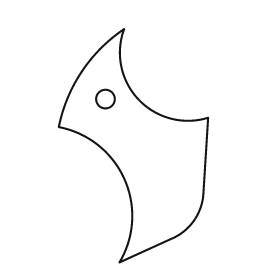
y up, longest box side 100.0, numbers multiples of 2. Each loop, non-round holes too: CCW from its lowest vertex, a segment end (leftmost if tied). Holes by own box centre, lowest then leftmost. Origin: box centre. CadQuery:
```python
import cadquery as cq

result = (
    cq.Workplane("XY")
    .moveTo(-6.0, -50.0)
    .lineTo(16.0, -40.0)
    .threePointArc((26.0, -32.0), (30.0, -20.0))
    .lineTo(32.0, 12.0)
    .threePointArc((2.0, 20.0), (-4.0, 50.0))
    .threePointArc((-22.0, 32.0), (-32.0, 8.0))
    .threePointArc((-4.0, -14.0), (-6.0, -50.0))
    .close()
    .moveTo(-12.0, 20.0)
    .circle(4.0)
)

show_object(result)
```